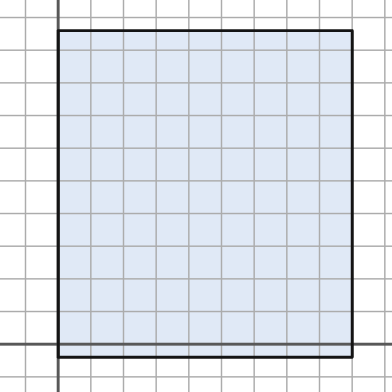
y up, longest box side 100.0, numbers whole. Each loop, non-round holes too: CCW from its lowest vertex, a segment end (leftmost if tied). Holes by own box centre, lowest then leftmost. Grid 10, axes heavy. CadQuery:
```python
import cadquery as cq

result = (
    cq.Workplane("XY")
    .moveTo(0.0, -4.0)
    .lineTo(90.0, -4.0)
    .lineTo(90.0, 96.0)
    .lineTo(0.0, 96.0)
    .close()
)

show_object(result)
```